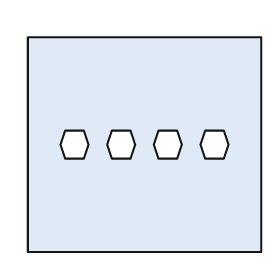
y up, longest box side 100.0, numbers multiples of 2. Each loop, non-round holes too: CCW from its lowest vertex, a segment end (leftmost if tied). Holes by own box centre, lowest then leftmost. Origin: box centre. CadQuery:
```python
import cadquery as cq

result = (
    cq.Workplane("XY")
    .moveTo(-50.0, -46.0)
    .lineTo(50.0, -46.0)
    .lineTo(50.0, 46.0)
    .lineTo(-50.0, 46.0)
    .close()
    .moveTo(-34.0, -6.0)
    .lineTo(-26.0, -6.0)
    .lineTo(-24.0, 0.0)
    .lineTo(-26.0, 6.0)
    .lineTo(-34.0, 6.0)
    .lineTo(-36.0, 0.0)
    .close()
    .moveTo(-14.0, -6.0)
    .lineTo(-6.0, -6.0)
    .lineTo(-4.0, 0.0)
    .lineTo(-6.0, 6.0)
    .lineTo(-14.0, 6.0)
    .lineTo(-16.0, 0.0)
    .close()
    .moveTo(6.0, -6.0)
    .lineTo(14.0, -6.0)
    .lineTo(16.0, 0.0)
    .lineTo(14.0, 6.0)
    .lineTo(6.0, 6.0)
    .lineTo(4.0, 0.0)
    .close()
    .moveTo(26.0, -6.0)
    .lineTo(34.0, -6.0)
    .lineTo(36.0, 0.0)
    .lineTo(34.0, 6.0)
    .lineTo(26.0, 6.0)
    .lineTo(24.0, 0.0)
    .close()
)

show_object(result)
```